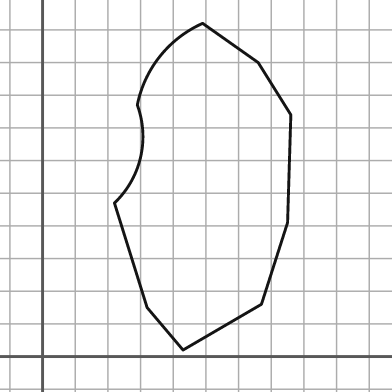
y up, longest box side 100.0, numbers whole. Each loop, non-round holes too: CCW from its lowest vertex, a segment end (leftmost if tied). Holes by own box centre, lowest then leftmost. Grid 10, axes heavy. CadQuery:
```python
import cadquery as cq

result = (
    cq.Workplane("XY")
    .moveTo(43.0, 2.0)
    .lineTo(67.0, 16.0)
    .lineTo(75.0, 41.0)
    .lineTo(76.0, 74.0)
    .lineTo(66.0, 90.0)
    .lineTo(49.0, 102.0)
    .threePointArc((36.0, 92.0), (29.0, 77.0))
    .threePointArc((30.0, 61.0), (22.0, 47.0))
    .lineTo(32.0, 15.0)
    .close()
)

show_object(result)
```